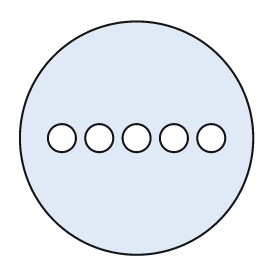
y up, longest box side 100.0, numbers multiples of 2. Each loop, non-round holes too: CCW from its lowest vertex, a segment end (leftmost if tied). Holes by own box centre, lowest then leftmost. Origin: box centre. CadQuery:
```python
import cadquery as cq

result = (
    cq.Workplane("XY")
    .moveTo(0.0, 0.0)
    .circle(50.0)
    .moveTo(-32.0, 0.0)
    .circle(6.0)
    .moveTo(-16.0, 0.0)
    .circle(6.0)
    .moveTo(0.0, 0.0)
    .circle(6.0)
    .moveTo(16.0, 0.0)
    .circle(6.0)
    .moveTo(32.0, 0.0)
    .circle(6.0)
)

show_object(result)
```